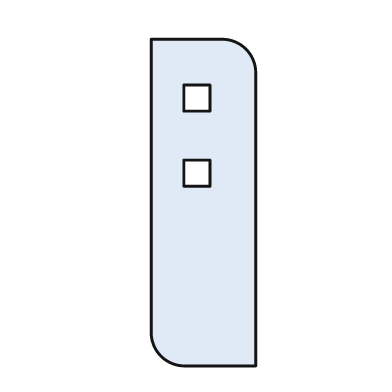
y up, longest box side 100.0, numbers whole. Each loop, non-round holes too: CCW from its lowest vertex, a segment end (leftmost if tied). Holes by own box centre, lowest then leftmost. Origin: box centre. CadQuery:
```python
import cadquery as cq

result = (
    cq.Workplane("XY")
    .moveTo(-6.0, -50.0)
    .lineTo(16.0, -50.0)
    .lineTo(16.0, 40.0)
    .threePointArc((13.0, 47.0), (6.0, 50.0))
    .lineTo(-16.0, 50.0)
    .lineTo(-16.0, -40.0)
    .threePointArc((-13.0, -47.0), (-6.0, -50.0))
    .close()
    .moveTo(-6.0, 5.0)
    .lineTo(2.0, 5.0)
    .lineTo(2.0, 13.0)
    .lineTo(-6.0, 13.0)
    .close()
    .moveTo(-6.0, 28.0)
    .lineTo(2.0, 28.0)
    .lineTo(2.0, 36.0)
    .lineTo(-6.0, 36.0)
    .close()
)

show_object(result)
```